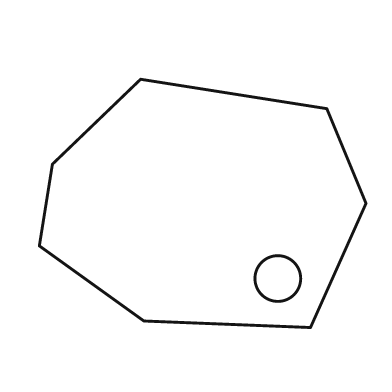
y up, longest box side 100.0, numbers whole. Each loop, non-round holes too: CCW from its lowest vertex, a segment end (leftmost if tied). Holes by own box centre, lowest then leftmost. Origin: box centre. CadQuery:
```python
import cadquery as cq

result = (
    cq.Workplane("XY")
    .moveTo(33.0, -38.0)
    .lineTo(50.0, 0.0)
    .lineTo(38.0, 29.0)
    .lineTo(-19.0, 38.0)
    .lineTo(-46.0, 12.0)
    .lineTo(-50.0, -13.0)
    .lineTo(-18.0, -36.0)
    .close()
    .moveTo(23.0, -23.0)
    .circle(7.0)
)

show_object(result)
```